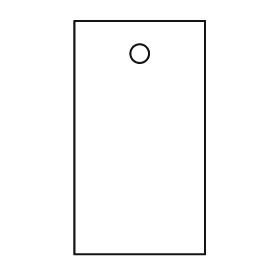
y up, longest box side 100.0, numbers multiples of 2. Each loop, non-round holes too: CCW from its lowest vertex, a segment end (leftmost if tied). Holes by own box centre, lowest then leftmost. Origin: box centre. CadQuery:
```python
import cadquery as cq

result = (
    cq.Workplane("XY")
    .moveTo(-28.0, -50.0)
    .lineTo(28.0, -50.0)
    .lineTo(28.0, 50.0)
    .lineTo(-28.0, 50.0)
    .close()
    .moveTo(0.0, 36.0)
    .circle(4.0)
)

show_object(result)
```